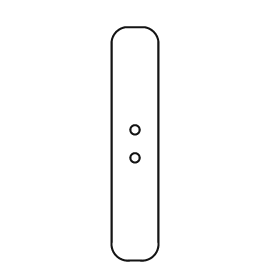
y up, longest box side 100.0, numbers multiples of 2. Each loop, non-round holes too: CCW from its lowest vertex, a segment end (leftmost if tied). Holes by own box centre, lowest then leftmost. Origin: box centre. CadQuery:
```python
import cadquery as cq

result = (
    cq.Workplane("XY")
    .moveTo(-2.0, -50.0)
    .lineTo(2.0, -50.0)
    .threePointArc((8.0, -48.0), (10.0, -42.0))
    .lineTo(10.0, 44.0)
    .threePointArc((8.0, 48.0), (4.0, 50.0))
    .lineTo(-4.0, 50.0)
    .threePointArc((-8.0, 48.0), (-10.0, 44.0))
    .lineTo(-10.0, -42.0)
    .threePointArc((-8.0, -48.0), (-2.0, -50.0))
    .close()
    .moveTo(0.0, -6.0)
    .circle(2.0)
    .moveTo(0.0, 6.0)
    .circle(2.0)
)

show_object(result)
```